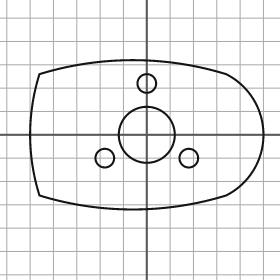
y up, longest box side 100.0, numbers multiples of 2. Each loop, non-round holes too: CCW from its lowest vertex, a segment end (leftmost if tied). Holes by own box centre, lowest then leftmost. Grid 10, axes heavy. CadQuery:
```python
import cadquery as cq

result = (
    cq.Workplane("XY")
    .moveTo(-46.0, -26.0)
    .threePointArc((-6.0, -32.0), (34.0, -26.0))
    .threePointArc((50.0, 0.0), (34.0, 26.0))
    .threePointArc((-6.0, 32.0), (-46.0, 26.0))
    .threePointArc((-50.0, 0.0), (-46.0, -26.0))
    .close()
    .moveTo(-18.0, -10.0)
    .circle(4.0)
    .moveTo(18.0, -10.0)
    .circle(4.0)
    .moveTo(0.0, 0.0)
    .circle(12.0)
    .moveTo(0.0, 22.0)
    .circle(4.0)
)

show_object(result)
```